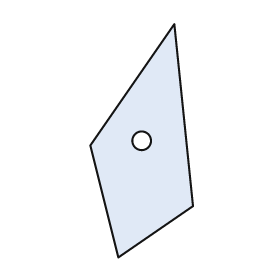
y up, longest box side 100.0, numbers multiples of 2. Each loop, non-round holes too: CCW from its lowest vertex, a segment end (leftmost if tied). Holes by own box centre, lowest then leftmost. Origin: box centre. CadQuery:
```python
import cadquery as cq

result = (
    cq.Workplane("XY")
    .moveTo(-10.0, -50.0)
    .lineTo(22.0, -28.0)
    .lineTo(14.0, 50.0)
    .lineTo(-22.0, -2.0)
    .close()
    .moveTo(0.0, 0.0)
    .circle(4.0)
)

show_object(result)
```